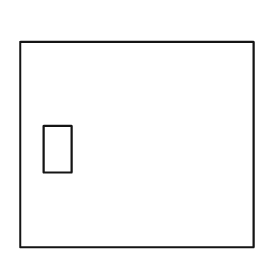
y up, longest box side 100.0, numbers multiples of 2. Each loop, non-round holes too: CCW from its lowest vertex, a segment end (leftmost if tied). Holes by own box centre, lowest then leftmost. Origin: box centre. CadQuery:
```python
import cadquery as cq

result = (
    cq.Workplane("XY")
    .moveTo(-50.0, -44.0)
    .lineTo(50.0, -44.0)
    .lineTo(50.0, 44.0)
    .lineTo(-50.0, 44.0)
    .close()
    .moveTo(-40.0, -12.0)
    .lineTo(-28.0, -12.0)
    .lineTo(-28.0, 8.0)
    .lineTo(-40.0, 8.0)
    .close()
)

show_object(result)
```